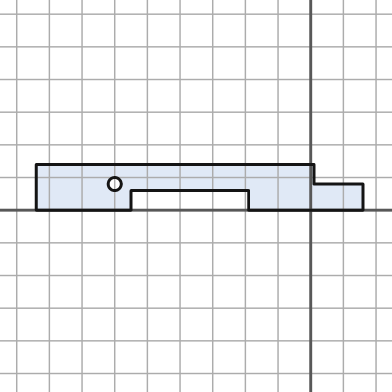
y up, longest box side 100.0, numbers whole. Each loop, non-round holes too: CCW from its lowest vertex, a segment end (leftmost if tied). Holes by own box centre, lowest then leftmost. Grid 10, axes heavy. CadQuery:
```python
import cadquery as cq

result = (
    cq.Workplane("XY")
    .moveTo(-84.0, 0.0)
    .lineTo(-55.0, 0.0)
    .lineTo(-55.0, 6.0)
    .lineTo(-19.0, 6.0)
    .lineTo(-19.0, 0.0)
    .lineTo(16.0, 0.0)
    .lineTo(16.0, 8.0)
    .lineTo(1.0, 8.0)
    .lineTo(1.0, 14.0)
    .lineTo(-84.0, 14.0)
    .close()
    .moveTo(-60.0, 8.0)
    .circle(2.0)
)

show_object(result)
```